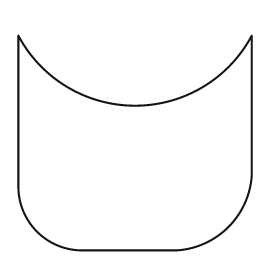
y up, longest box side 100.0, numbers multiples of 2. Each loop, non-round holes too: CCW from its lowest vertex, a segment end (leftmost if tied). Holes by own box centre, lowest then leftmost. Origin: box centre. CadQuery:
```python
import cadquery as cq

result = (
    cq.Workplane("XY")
    .moveTo(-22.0, -46.0)
    .lineTo(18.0, -46.0)
    .threePointArc((40.0, -36.0), (50.0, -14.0))
    .lineTo(50.0, 46.0)
    .threePointArc((0.0, 16.0), (-50.0, 46.0))
    .lineTo(-50.0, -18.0)
    .threePointArc((-42.0, -38.0), (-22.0, -46.0))
    .close()
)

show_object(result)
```